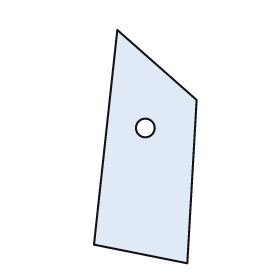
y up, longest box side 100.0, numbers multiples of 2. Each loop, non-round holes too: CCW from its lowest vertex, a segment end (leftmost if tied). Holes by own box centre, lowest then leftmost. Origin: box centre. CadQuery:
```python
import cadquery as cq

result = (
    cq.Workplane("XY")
    .moveTo(18.0, -50.0)
    .lineTo(22.0, 20.0)
    .lineTo(-12.0, 50.0)
    .lineTo(-22.0, -42.0)
    .close()
    .moveTo(0.0, 8.0)
    .circle(4.0)
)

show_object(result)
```